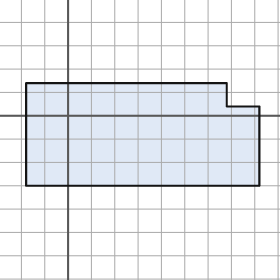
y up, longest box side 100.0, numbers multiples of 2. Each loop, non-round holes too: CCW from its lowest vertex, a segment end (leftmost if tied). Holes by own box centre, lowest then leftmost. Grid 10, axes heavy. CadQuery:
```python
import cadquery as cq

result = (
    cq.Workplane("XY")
    .moveTo(-18.0, -30.0)
    .lineTo(82.0, -30.0)
    .lineTo(82.0, 4.0)
    .lineTo(68.0, 4.0)
    .lineTo(68.0, 14.0)
    .lineTo(-18.0, 14.0)
    .close()
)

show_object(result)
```